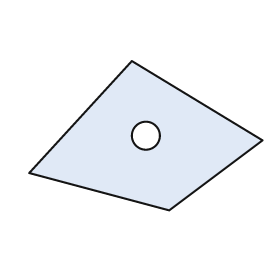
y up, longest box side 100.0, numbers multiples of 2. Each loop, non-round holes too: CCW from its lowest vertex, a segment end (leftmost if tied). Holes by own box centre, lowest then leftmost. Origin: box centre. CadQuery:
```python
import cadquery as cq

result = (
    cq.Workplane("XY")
    .moveTo(10.0, -32.0)
    .lineTo(50.0, -2.0)
    .lineTo(-6.0, 32.0)
    .lineTo(-50.0, -16.0)
    .close()
    .moveTo(0.0, 0.0)
    .circle(6.0)
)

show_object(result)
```